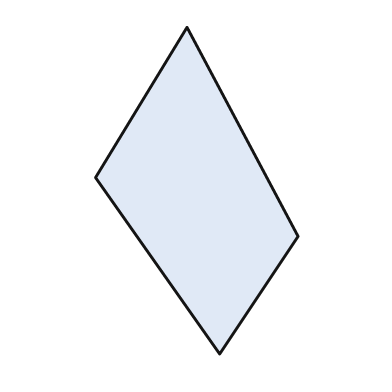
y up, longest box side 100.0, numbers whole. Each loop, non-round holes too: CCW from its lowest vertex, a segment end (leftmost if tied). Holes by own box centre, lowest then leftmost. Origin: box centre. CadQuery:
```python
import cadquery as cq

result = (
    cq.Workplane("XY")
    .moveTo(7.0, -50.0)
    .lineTo(31.0, -14.0)
    .lineTo(-3.0, 50.0)
    .lineTo(-31.0, 4.0)
    .close()
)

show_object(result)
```